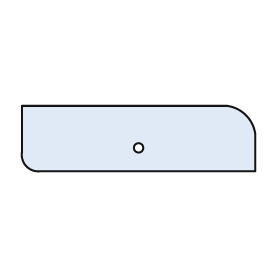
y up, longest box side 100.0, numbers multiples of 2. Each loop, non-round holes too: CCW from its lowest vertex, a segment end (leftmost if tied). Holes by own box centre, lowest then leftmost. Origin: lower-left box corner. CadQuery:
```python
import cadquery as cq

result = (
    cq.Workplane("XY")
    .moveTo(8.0, 0.0)
    .lineTo(100.0, 0.0)
    .lineTo(100.0, 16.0)
    .threePointArc((96.0, 24.0), (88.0, 28.0))
    .lineTo(0.0, 28.0)
    .lineTo(0.0, 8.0)
    .threePointArc((2.0, 2.0), (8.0, 0.0))
    .close()
    .moveTo(50.0, 10.0)
    .circle(2.0)
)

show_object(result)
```